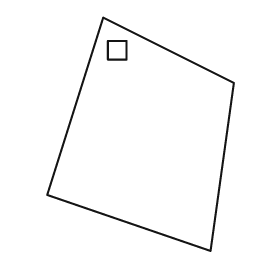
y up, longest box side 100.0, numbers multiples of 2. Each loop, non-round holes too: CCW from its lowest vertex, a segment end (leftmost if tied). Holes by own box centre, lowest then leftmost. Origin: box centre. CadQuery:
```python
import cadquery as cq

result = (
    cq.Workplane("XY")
    .moveTo(30.0, -50.0)
    .lineTo(40.0, 22.0)
    .lineTo(-16.0, 50.0)
    .lineTo(-40.0, -26.0)
    .close()
    .moveTo(-14.0, 32.0)
    .lineTo(-6.0, 32.0)
    .lineTo(-6.0, 40.0)
    .lineTo(-14.0, 40.0)
    .close()
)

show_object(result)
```